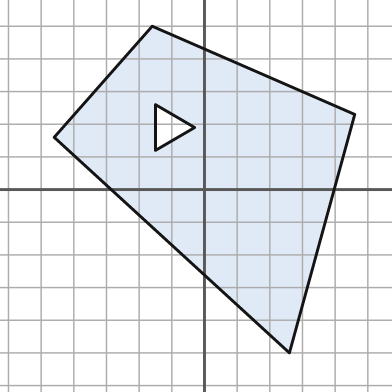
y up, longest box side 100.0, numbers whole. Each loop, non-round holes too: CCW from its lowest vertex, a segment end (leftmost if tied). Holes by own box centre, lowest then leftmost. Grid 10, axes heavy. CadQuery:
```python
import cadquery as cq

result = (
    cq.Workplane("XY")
    .moveTo(26.0, -50.0)
    .lineTo(46.0, 23.0)
    .lineTo(-16.0, 50.0)
    .lineTo(-46.0, 16.0)
    .close()
    .moveTo(-15.0, 12.0)
    .lineTo(-3.0, 19.0)
    .lineTo(-15.0, 26.0)
    .close()
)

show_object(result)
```